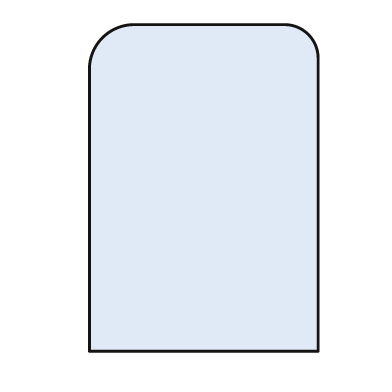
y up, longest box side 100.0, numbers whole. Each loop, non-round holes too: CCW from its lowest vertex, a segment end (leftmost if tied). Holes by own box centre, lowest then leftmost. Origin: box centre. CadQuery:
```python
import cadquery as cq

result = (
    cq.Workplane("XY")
    .moveTo(-35.0, -50.0)
    .lineTo(35.0, -50.0)
    .lineTo(35.0, 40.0)
    .threePointArc((32.0, 47.0), (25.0, 50.0))
    .lineTo(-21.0, 50.0)
    .threePointArc((-31.0, 46.0), (-35.0, 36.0))
    .close()
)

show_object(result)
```